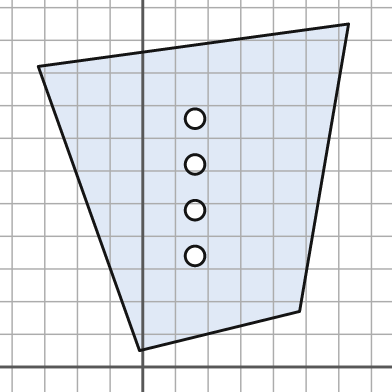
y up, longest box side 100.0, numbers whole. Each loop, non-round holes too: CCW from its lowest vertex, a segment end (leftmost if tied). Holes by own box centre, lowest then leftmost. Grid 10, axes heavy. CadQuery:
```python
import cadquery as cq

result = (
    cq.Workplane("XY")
    .moveTo(-1.0, 5.0)
    .lineTo(48.0, 17.0)
    .lineTo(63.0, 105.0)
    .lineTo(-32.0, 92.0)
    .close()
    .moveTo(16.0, 34.0)
    .circle(3.0)
    .moveTo(16.0, 48.0)
    .circle(3.0)
    .moveTo(16.0, 62.0)
    .circle(3.0)
    .moveTo(16.0, 76.0)
    .circle(3.0)
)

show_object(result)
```